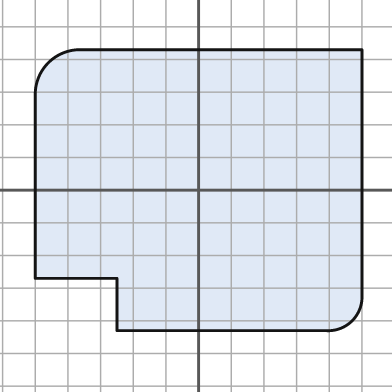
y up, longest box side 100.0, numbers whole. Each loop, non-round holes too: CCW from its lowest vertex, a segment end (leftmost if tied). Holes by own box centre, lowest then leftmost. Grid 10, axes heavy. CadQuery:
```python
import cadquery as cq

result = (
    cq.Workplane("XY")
    .moveTo(-25.0, -43.0)
    .lineTo(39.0, -43.0)
    .threePointArc((47.0, -40.0), (50.0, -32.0))
    .lineTo(50.0, 43.0)
    .lineTo(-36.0, 43.0)
    .threePointArc((-46.0, 39.0), (-50.0, 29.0))
    .lineTo(-50.0, -27.0)
    .lineTo(-25.0, -27.0)
    .close()
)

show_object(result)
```